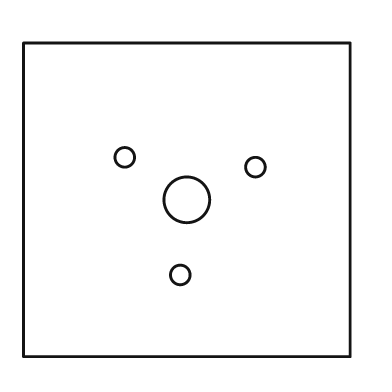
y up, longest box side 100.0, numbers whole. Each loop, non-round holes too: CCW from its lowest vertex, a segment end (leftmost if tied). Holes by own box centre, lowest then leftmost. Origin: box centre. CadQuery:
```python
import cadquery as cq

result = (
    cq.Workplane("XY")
    .moveTo(-50.0, -48.0)
    .lineTo(50.0, -48.0)
    .lineTo(50.0, 48.0)
    .lineTo(-50.0, 48.0)
    .close()
    .moveTo(-2.0, -23.0)
    .circle(3.0)
    .moveTo(0.0, 0.0)
    .circle(7.0)
    .moveTo(21.0, 10.0)
    .circle(3.0)
    .moveTo(-19.0, 13.0)
    .circle(3.0)
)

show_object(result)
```